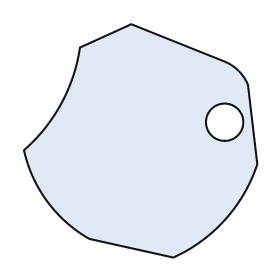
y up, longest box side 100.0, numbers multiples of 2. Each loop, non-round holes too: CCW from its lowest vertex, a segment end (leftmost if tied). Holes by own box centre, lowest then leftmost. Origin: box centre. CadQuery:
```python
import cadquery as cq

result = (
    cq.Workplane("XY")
    .moveTo(14.0, -50.0)
    .threePointArc((36.0, -34.0), (50.0, -10.0))
    .lineTo(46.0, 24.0)
    .threePointArc((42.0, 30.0), (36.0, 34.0))
    .lineTo(-4.0, 50.0)
    .lineTo(-26.0, 40.0)
    .threePointArc((-34.0, 16.0), (-50.0, -4.0))
    .threePointArc((-40.0, -26.0), (-22.0, -42.0))
    .close()
    .moveTo(36.0, 8.0)
    .circle(8.0)
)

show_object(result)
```